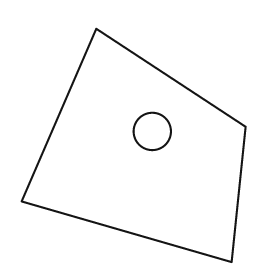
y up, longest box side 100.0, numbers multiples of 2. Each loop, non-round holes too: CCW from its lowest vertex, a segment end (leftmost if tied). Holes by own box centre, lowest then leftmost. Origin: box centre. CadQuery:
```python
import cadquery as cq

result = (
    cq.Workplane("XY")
    .moveTo(42.0, -50.0)
    .lineTo(48.0, 8.0)
    .lineTo(-16.0, 50.0)
    .lineTo(-48.0, -24.0)
    .close()
    .moveTo(8.0, 6.0)
    .circle(8.0)
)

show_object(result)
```